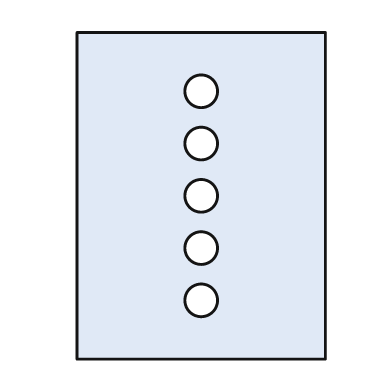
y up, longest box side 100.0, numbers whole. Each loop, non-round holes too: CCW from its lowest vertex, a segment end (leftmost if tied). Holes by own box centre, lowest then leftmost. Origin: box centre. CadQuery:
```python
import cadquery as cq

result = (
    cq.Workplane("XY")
    .moveTo(-38.0, -50.0)
    .lineTo(38.0, -50.0)
    .lineTo(38.0, 50.0)
    .lineTo(-38.0, 50.0)
    .close()
    .moveTo(0.0, -32.0)
    .circle(5.0)
    .moveTo(0.0, -16.0)
    .circle(5.0)
    .moveTo(0.0, 0.0)
    .circle(5.0)
    .moveTo(0.0, 16.0)
    .circle(5.0)
    .moveTo(0.0, 32.0)
    .circle(5.0)
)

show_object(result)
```